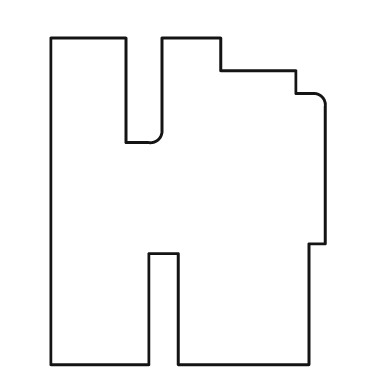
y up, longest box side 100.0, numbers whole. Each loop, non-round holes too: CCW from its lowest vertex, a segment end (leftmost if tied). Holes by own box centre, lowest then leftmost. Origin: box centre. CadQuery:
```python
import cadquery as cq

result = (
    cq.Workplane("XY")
    .moveTo(-42.0, -50.0)
    .lineTo(-12.0, -50.0)
    .lineTo(-12.0, -16.0)
    .lineTo(-3.0, -16.0)
    .lineTo(-3.0, -50.0)
    .lineTo(37.0, -50.0)
    .lineTo(37.0, -13.0)
    .lineTo(42.0, -13.0)
    .lineTo(42.0, 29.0)
    .threePointArc((41.0, 32.0), (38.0, 33.0))
    .lineTo(33.0, 33.0)
    .lineTo(33.0, 40.0)
    .lineTo(10.0, 40.0)
    .lineTo(10.0, 50.0)
    .lineTo(-8.0, 50.0)
    .lineTo(-8.0, 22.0)
    .threePointArc((-9.0, 19.0), (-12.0, 18.0))
    .lineTo(-19.0, 18.0)
    .lineTo(-19.0, 50.0)
    .lineTo(-42.0, 50.0)
    .close()
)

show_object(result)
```